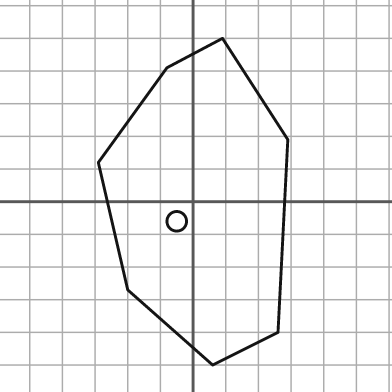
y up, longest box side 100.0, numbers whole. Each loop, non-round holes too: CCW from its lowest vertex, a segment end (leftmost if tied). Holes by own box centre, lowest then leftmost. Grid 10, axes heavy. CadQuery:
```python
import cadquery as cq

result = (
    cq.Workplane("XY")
    .moveTo(6.0, -50.0)
    .lineTo(26.0, -40.0)
    .lineTo(29.0, 19.0)
    .lineTo(9.0, 50.0)
    .lineTo(-8.0, 41.0)
    .lineTo(-29.0, 12.0)
    .lineTo(-20.0, -27.0)
    .close()
    .moveTo(-5.0, -6.0)
    .circle(3.0)
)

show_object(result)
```